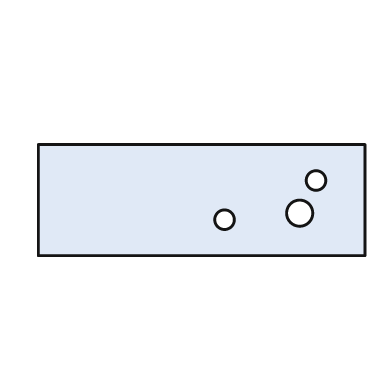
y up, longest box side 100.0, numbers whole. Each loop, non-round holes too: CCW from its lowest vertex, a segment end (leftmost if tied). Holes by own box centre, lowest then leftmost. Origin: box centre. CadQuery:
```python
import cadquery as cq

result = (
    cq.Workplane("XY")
    .moveTo(-50.0, -17.0)
    .lineTo(50.0, -17.0)
    .lineTo(50.0, 17.0)
    .lineTo(-50.0, 17.0)
    .close()
    .moveTo(7.0, -6.0)
    .circle(3.0)
    .moveTo(30.0, -4.0)
    .circle(4.0)
    .moveTo(35.0, 6.0)
    .circle(3.0)
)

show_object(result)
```